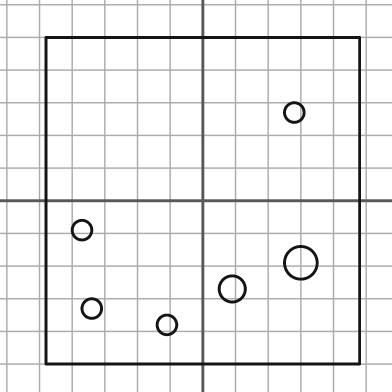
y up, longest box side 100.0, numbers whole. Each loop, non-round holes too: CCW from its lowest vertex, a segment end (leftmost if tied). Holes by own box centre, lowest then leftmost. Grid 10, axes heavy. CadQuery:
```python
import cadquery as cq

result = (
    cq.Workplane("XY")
    .moveTo(-48.0, -50.0)
    .lineTo(48.0, -50.0)
    .lineTo(48.0, 50.0)
    .lineTo(-48.0, 50.0)
    .close()
    .moveTo(-11.0, -38.0)
    .circle(3.0)
    .moveTo(-34.0, -33.0)
    .circle(3.0)
    .moveTo(9.0, -27.0)
    .circle(4.0)
    .moveTo(30.0, -19.0)
    .circle(5.0)
    .moveTo(-37.0, -9.0)
    .circle(3.0)
    .moveTo(28.0, 27.0)
    .circle(3.0)
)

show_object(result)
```